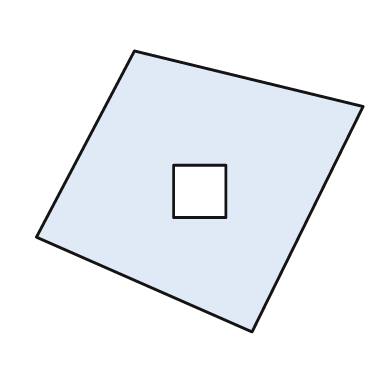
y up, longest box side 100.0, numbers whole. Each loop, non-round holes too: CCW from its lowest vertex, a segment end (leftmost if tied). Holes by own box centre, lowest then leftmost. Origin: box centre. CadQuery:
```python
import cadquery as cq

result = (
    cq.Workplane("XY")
    .moveTo(16.0, -43.0)
    .lineTo(50.0, 26.0)
    .lineTo(-20.0, 43.0)
    .lineTo(-50.0, -14.0)
    .close()
    .moveTo(-8.0, -8.0)
    .lineTo(8.0, -8.0)
    .lineTo(8.0, 8.0)
    .lineTo(-8.0, 8.0)
    .close()
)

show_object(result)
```